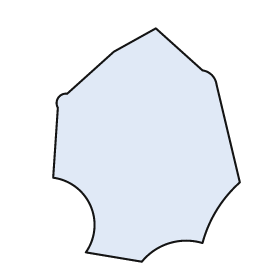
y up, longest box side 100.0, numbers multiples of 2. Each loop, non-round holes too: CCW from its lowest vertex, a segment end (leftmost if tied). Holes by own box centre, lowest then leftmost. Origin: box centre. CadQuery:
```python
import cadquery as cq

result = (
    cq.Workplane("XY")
    .moveTo(-2.0, -50.0)
    .threePointArc((10.0, -42.0), (24.0, -42.0))
    .threePointArc((30.0, -28.0), (40.0, -16.0))
    .lineTo(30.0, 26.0)
    .threePointArc((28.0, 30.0), (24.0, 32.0))
    .lineTo(4.0, 50.0)
    .lineTo(-14.0, 40.0)
    .lineTo(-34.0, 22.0)
    .threePointArc((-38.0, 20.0), (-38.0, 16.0))
    .lineTo(-40.0, -14.0)
    .threePointArc((-24.0, -26.0), (-26.0, -46.0))
    .close()
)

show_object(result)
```